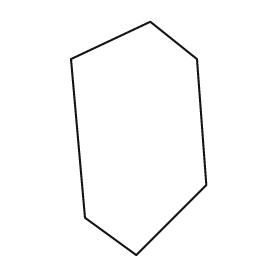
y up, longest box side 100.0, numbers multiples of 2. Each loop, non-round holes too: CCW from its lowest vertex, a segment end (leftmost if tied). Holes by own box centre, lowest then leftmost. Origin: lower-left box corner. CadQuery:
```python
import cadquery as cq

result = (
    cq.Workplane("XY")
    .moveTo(28.0, 0.0)
    .lineTo(58.0, 30.0)
    .lineTo(54.0, 84.0)
    .lineTo(34.0, 100.0)
    .lineTo(0.0, 84.0)
    .lineTo(6.0, 16.0)
    .close()
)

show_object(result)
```